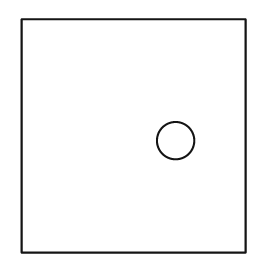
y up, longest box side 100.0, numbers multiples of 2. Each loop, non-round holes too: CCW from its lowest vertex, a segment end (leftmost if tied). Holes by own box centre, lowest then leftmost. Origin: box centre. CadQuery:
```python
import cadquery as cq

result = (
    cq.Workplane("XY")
    .moveTo(-48.0, -50.0)
    .lineTo(48.0, -50.0)
    .lineTo(48.0, 50.0)
    .lineTo(-48.0, 50.0)
    .close()
    .moveTo(18.0, -2.0)
    .circle(8.0)
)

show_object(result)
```